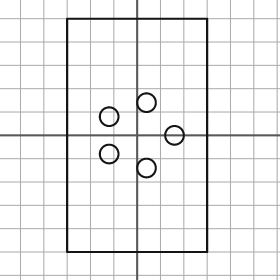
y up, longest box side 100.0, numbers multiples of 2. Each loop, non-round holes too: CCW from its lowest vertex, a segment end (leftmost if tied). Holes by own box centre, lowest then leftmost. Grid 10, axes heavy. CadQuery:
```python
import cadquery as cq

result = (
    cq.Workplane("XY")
    .moveTo(-30.0, -50.0)
    .lineTo(30.0, -50.0)
    .lineTo(30.0, 50.0)
    .lineTo(-30.0, 50.0)
    .close()
    .moveTo(4.0, -14.0)
    .circle(4.0)
    .moveTo(-12.0, -8.0)
    .circle(4.0)
    .moveTo(16.0, 0.0)
    .circle(4.0)
    .moveTo(-12.0, 8.0)
    .circle(4.0)
    .moveTo(4.0, 14.0)
    .circle(4.0)
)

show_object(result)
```